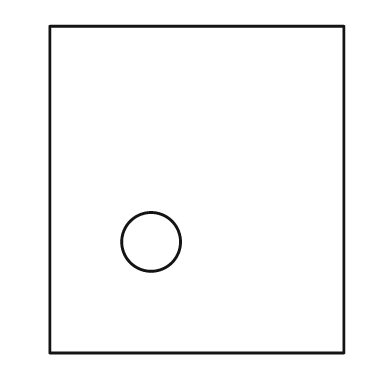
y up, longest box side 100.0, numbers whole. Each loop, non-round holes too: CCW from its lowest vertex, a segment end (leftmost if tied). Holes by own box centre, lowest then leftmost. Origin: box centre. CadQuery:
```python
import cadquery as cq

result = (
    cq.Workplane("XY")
    .moveTo(-45.0, -50.0)
    .lineTo(45.0, -50.0)
    .lineTo(45.0, 50.0)
    .lineTo(-45.0, 50.0)
    .close()
    .moveTo(-14.0, -16.0)
    .circle(9.0)
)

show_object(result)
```